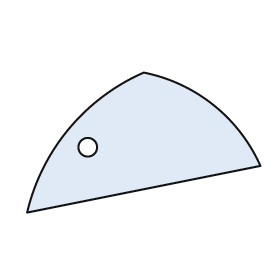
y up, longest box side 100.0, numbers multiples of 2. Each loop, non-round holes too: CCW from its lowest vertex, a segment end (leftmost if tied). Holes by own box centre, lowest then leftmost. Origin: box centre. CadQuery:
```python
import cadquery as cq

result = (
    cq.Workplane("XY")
    .moveTo(-50.0, -30.0)
    .lineTo(50.0, -10.0)
    .threePointArc((30.0, 16.0), (0.0, 30.0))
    .threePointArc((-32.0, 6.0), (-50.0, -30.0))
    .close()
    .moveTo(-24.0, -2.0)
    .circle(4.0)
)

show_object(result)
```